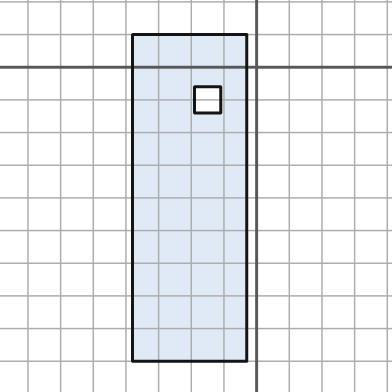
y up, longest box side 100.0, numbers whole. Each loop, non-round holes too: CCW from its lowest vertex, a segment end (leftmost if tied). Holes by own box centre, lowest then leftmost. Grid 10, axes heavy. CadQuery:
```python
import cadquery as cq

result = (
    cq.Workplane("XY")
    .moveTo(-38.0, -90.0)
    .lineTo(-3.0, -90.0)
    .lineTo(-3.0, 10.0)
    .lineTo(-38.0, 10.0)
    .close()
    .moveTo(-19.0, -14.0)
    .lineTo(-11.0, -14.0)
    .lineTo(-11.0, -6.0)
    .lineTo(-19.0, -6.0)
    .close()
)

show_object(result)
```